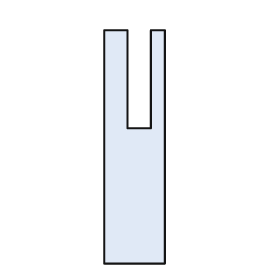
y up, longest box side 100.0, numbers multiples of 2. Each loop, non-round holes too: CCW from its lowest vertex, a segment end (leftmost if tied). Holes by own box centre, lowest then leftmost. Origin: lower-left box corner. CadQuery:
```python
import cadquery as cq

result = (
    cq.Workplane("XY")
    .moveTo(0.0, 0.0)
    .lineTo(26.0, 0.0)
    .lineTo(26.0, 100.0)
    .lineTo(20.0, 100.0)
    .lineTo(20.0, 58.0)
    .lineTo(10.0, 58.0)
    .lineTo(10.0, 100.0)
    .lineTo(0.0, 100.0)
    .close()
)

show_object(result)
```